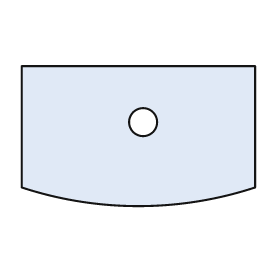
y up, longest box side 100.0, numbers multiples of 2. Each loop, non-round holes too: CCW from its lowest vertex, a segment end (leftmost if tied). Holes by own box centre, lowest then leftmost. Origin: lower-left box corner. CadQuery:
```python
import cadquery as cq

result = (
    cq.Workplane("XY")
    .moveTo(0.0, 8.0)
    .threePointArc((50.0, 0.0), (100.0, 8.0))
    .lineTo(100.0, 60.0)
    .lineTo(0.0, 60.0)
    .close()
    .moveTo(52.0, 36.0)
    .circle(6.0)
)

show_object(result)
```